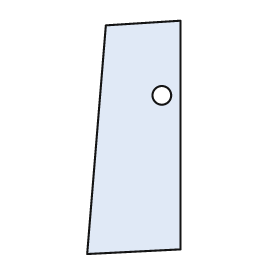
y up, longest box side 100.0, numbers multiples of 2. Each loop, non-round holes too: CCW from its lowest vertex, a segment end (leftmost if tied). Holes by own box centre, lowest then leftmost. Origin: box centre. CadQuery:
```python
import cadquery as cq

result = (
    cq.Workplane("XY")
    .moveTo(-20.0, -50.0)
    .lineTo(20.0, -48.0)
    .lineTo(20.0, 50.0)
    .lineTo(-12.0, 48.0)
    .close()
    .moveTo(12.0, 18.0)
    .circle(4.0)
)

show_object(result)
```